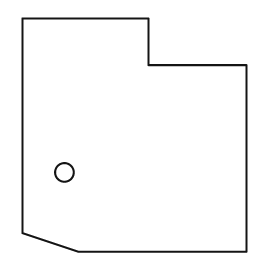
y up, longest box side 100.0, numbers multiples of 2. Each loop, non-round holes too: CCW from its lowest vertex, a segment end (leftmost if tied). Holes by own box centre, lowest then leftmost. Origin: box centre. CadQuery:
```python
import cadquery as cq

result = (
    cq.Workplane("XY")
    .moveTo(-24.0, -50.0)
    .lineTo(48.0, -50.0)
    .lineTo(48.0, 30.0)
    .lineTo(6.0, 30.0)
    .lineTo(6.0, 50.0)
    .lineTo(-48.0, 50.0)
    .lineTo(-48.0, -42.0)
    .close()
    .moveTo(-30.0, -16.0)
    .circle(4.0)
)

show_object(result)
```